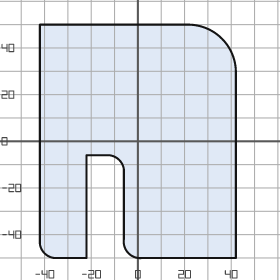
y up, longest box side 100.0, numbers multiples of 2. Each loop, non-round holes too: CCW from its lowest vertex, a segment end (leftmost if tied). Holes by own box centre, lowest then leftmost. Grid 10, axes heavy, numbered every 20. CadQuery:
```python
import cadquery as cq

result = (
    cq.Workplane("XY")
    .moveTo(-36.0, -50.0)
    .lineTo(-22.0, -50.0)
    .lineTo(-22.0, -6.0)
    .lineTo(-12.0, -6.0)
    .threePointArc((-8.0, -8.0), (-6.0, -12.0))
    .lineTo(-6.0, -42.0)
    .threePointArc((-4.0, -48.0), (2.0, -50.0))
    .lineTo(42.0, -50.0)
    .lineTo(42.0, 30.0)
    .threePointArc((36.0, 44.0), (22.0, 50.0))
    .lineTo(-42.0, 50.0)
    .lineTo(-42.0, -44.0)
    .threePointArc((-40.0, -48.0), (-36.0, -50.0))
    .close()
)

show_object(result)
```